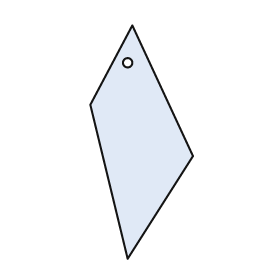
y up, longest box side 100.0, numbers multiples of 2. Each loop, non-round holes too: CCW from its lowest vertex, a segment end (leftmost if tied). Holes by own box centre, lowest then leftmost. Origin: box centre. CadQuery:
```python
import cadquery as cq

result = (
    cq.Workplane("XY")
    .moveTo(-6.0, -50.0)
    .lineTo(22.0, -6.0)
    .lineTo(-4.0, 50.0)
    .lineTo(-22.0, 16.0)
    .close()
    .moveTo(-6.0, 34.0)
    .circle(2.0)
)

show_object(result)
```